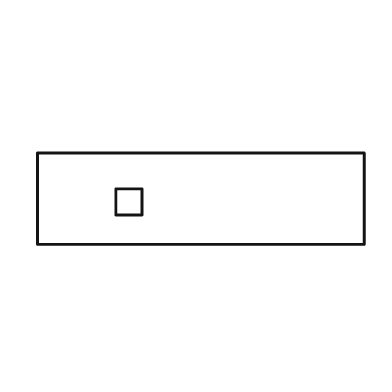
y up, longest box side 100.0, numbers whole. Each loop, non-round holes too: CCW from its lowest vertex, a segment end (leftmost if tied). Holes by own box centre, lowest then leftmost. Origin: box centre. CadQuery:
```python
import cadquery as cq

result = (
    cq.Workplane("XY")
    .moveTo(-50.0, -14.0)
    .lineTo(50.0, -14.0)
    .lineTo(50.0, 14.0)
    .lineTo(-50.0, 14.0)
    .close()
    .moveTo(-26.0, -5.0)
    .lineTo(-18.0, -5.0)
    .lineTo(-18.0, 3.0)
    .lineTo(-26.0, 3.0)
    .close()
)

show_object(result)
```